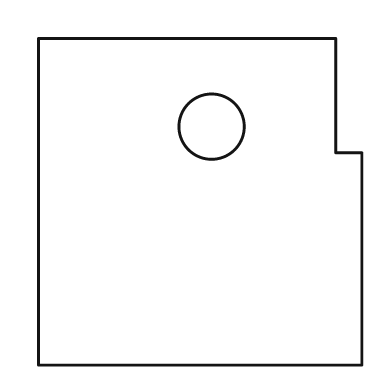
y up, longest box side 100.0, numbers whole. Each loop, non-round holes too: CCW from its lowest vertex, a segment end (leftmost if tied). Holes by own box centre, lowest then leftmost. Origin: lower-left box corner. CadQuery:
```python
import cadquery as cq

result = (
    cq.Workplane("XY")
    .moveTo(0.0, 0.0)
    .lineTo(99.0, 0.0)
    .lineTo(99.0, 65.0)
    .lineTo(91.0, 65.0)
    .lineTo(91.0, 100.0)
    .lineTo(0.0, 100.0)
    .close()
    .moveTo(53.0, 73.0)
    .circle(10.0)
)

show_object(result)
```